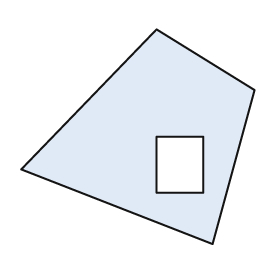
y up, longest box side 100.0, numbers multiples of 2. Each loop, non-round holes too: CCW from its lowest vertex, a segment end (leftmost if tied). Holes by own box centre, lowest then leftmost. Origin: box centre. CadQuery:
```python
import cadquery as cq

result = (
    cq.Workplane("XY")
    .moveTo(32.0, -46.0)
    .lineTo(50.0, 20.0)
    .lineTo(8.0, 46.0)
    .lineTo(-50.0, -14.0)
    .close()
    .moveTo(8.0, -24.0)
    .lineTo(28.0, -24.0)
    .lineTo(28.0, 0.0)
    .lineTo(8.0, 0.0)
    .close()
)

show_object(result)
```